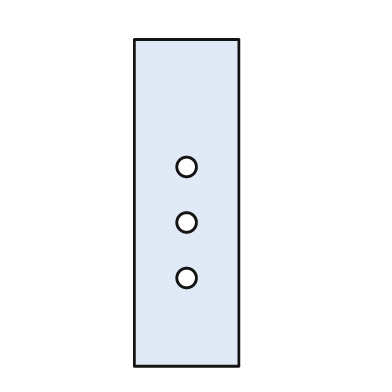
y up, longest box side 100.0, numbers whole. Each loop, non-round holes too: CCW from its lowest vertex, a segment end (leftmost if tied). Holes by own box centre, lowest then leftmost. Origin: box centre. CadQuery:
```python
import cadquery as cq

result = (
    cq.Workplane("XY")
    .moveTo(-16.0, -50.0)
    .lineTo(16.0, -50.0)
    .lineTo(16.0, 50.0)
    .lineTo(-16.0, 50.0)
    .close()
    .moveTo(0.0, -23.0)
    .circle(3.0)
    .moveTo(0.0, -6.0)
    .circle(3.0)
    .moveTo(0.0, 11.0)
    .circle(3.0)
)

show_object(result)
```